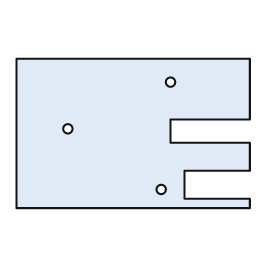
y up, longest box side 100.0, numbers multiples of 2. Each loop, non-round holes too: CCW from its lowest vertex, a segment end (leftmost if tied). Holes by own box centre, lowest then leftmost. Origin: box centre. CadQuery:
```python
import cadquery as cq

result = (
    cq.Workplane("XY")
    .moveTo(-50.0, -32.0)
    .lineTo(50.0, -32.0)
    .lineTo(50.0, -28.0)
    .lineTo(22.0, -28.0)
    .lineTo(22.0, -16.0)
    .lineTo(50.0, -16.0)
    .lineTo(50.0, -4.0)
    .lineTo(16.0, -4.0)
    .lineTo(16.0, 6.0)
    .lineTo(50.0, 6.0)
    .lineTo(50.0, 32.0)
    .lineTo(-50.0, 32.0)
    .close()
    .moveTo(12.0, -24.0)
    .circle(2.0)
    .moveTo(-28.0, 2.0)
    .circle(2.0)
    .moveTo(16.0, 22.0)
    .circle(2.0)
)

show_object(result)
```